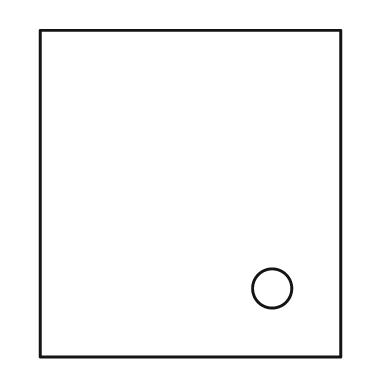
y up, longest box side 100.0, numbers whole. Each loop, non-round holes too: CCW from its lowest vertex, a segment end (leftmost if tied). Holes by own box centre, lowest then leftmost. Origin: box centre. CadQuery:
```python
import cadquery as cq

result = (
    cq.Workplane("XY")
    .moveTo(-46.0, -50.0)
    .lineTo(46.0, -50.0)
    .lineTo(46.0, 50.0)
    .lineTo(-46.0, 50.0)
    .close()
    .moveTo(25.0, -29.0)
    .circle(6.0)
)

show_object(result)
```